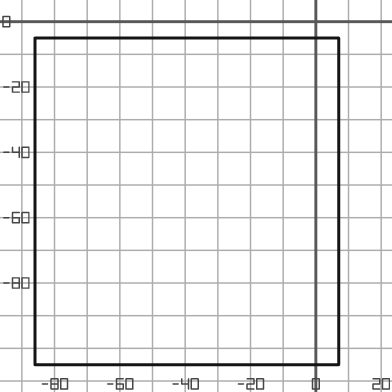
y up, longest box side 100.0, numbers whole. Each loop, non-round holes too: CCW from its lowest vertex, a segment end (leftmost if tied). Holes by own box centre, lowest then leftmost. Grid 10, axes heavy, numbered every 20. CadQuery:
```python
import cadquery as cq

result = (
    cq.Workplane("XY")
    .moveTo(-86.0, -105.0)
    .lineTo(7.0, -105.0)
    .lineTo(7.0, -5.0)
    .lineTo(-86.0, -5.0)
    .close()
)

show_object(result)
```